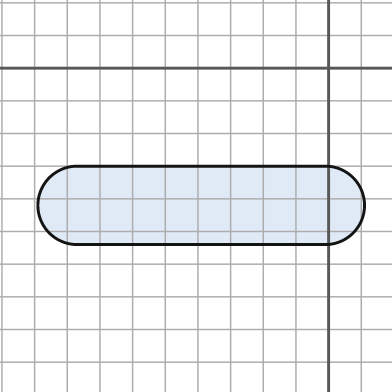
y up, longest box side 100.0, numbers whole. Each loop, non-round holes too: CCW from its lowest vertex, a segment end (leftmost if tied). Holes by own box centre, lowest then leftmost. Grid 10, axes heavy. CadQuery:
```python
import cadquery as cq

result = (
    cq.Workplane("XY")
    .moveTo(-77.0, -54.0)
    .lineTo(-1.0, -54.0)
    .threePointArc((11.0, -42.0), (-1.0, -30.0))
    .lineTo(-77.0, -30.0)
    .threePointArc((-89.0, -42.0), (-77.0, -54.0))
    .close()
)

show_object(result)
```